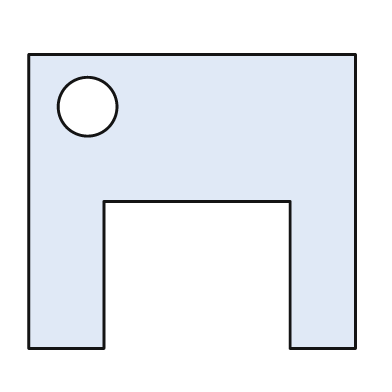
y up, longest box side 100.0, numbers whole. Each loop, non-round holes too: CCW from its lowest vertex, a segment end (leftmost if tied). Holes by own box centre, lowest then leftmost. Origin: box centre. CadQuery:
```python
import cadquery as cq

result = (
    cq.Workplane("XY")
    .moveTo(-50.0, -45.0)
    .lineTo(-27.0, -45.0)
    .lineTo(-27.0, 0.0)
    .lineTo(30.0, 0.0)
    .lineTo(30.0, -45.0)
    .lineTo(50.0, -45.0)
    .lineTo(50.0, 45.0)
    .lineTo(-50.0, 45.0)
    .close()
    .moveTo(-32.0, 29.0)
    .circle(9.0)
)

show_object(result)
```